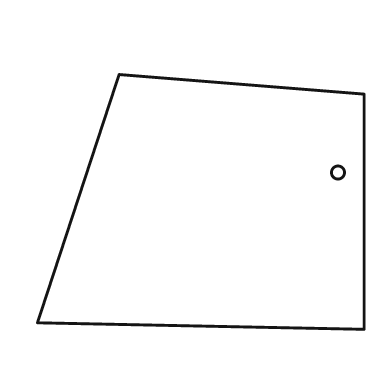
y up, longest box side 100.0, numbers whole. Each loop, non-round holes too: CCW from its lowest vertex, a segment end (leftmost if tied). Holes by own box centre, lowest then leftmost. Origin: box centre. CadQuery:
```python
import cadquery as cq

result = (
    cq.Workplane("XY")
    .moveTo(50.0, -39.0)
    .lineTo(50.0, 33.0)
    .lineTo(-25.0, 39.0)
    .lineTo(-50.0, -37.0)
    .close()
    .moveTo(42.0, 9.0)
    .circle(2.0)
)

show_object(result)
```